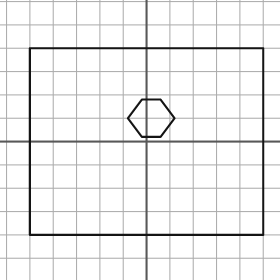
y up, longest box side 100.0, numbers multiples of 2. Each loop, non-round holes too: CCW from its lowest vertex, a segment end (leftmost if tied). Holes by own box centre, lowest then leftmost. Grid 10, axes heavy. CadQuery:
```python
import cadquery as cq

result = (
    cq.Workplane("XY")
    .moveTo(-50.0, -40.0)
    .lineTo(50.0, -40.0)
    .lineTo(50.0, 40.0)
    .lineTo(-50.0, 40.0)
    .close()
    .moveTo(-2.0, 2.0)
    .lineTo(6.0, 2.0)
    .lineTo(12.0, 10.0)
    .lineTo(6.0, 18.0)
    .lineTo(-2.0, 18.0)
    .lineTo(-8.0, 10.0)
    .close()
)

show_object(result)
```